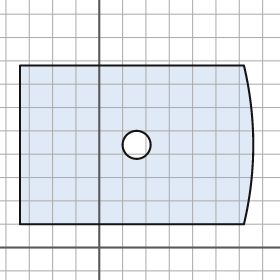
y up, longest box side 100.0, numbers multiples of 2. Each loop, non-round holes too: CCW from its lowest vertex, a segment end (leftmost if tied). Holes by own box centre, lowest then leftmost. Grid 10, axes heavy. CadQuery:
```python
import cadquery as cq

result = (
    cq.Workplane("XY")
    .moveTo(-34.0, 10.0)
    .lineTo(62.0, 10.0)
    .threePointArc((66.0, 44.0), (62.0, 78.0))
    .lineTo(-34.0, 78.0)
    .close()
    .moveTo(16.0, 44.0)
    .circle(6.0)
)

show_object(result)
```